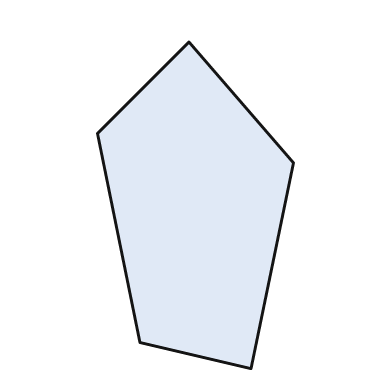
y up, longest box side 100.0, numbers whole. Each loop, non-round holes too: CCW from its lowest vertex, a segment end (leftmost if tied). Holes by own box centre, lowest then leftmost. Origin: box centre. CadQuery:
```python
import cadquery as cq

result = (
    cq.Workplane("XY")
    .moveTo(17.0, -50.0)
    .lineTo(30.0, 13.0)
    .lineTo(-2.0, 50.0)
    .lineTo(-30.0, 22.0)
    .lineTo(-17.0, -42.0)
    .close()
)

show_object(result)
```